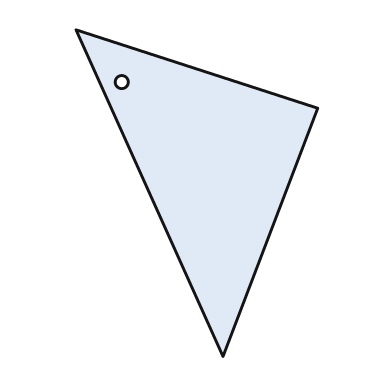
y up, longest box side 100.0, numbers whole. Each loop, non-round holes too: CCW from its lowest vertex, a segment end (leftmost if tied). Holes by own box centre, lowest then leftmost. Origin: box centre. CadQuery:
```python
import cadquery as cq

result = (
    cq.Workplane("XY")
    .moveTo(8.0, -50.0)
    .lineTo(37.0, 26.0)
    .lineTo(-37.0, 50.0)
    .close()
    .moveTo(-23.0, 34.0)
    .circle(2.0)
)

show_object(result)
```